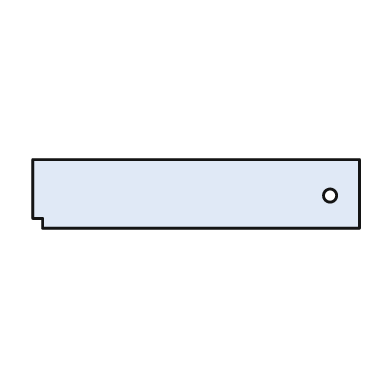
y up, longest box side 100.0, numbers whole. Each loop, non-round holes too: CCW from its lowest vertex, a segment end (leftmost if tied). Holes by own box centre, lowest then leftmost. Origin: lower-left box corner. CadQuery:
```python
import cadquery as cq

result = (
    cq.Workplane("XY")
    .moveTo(3.0, 0.0)
    .lineTo(100.0, 0.0)
    .lineTo(100.0, 21.0)
    .lineTo(0.0, 21.0)
    .lineTo(0.0, 3.0)
    .lineTo(3.0, 3.0)
    .close()
    .moveTo(91.0, 10.0)
    .circle(2.0)
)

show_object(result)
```